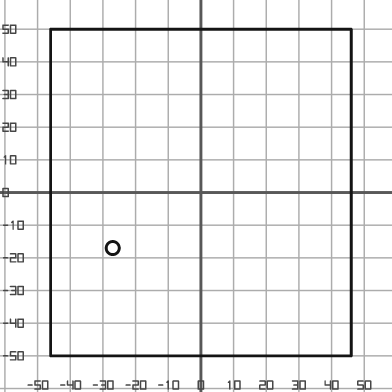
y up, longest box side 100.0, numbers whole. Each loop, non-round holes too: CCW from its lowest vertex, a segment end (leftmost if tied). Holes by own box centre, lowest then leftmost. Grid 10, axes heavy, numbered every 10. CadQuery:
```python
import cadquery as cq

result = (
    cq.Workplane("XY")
    .moveTo(-46.0, -50.0)
    .lineTo(46.0, -50.0)
    .lineTo(46.0, 50.0)
    .lineTo(-46.0, 50.0)
    .close()
    .moveTo(-27.0, -17.0)
    .circle(2.0)
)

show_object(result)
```